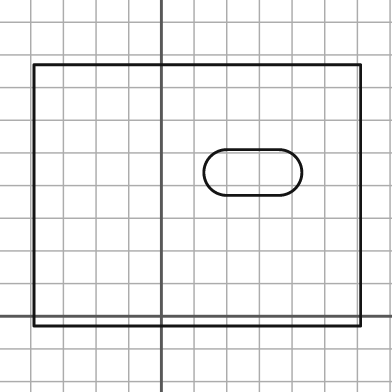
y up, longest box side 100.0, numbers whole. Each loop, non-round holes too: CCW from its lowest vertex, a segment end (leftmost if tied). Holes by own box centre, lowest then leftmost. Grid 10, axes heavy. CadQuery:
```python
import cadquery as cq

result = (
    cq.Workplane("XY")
    .moveTo(-39.0, -3.0)
    .lineTo(61.0, -3.0)
    .lineTo(61.0, 77.0)
    .lineTo(-39.0, 77.0)
    .close()
    .moveTo(20.0, 37.0)
    .lineTo(36.0, 37.0)
    .threePointArc((43.0, 44.0), (36.0, 51.0))
    .lineTo(20.0, 51.0)
    .threePointArc((13.0, 44.0), (20.0, 37.0))
    .close()
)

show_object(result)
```